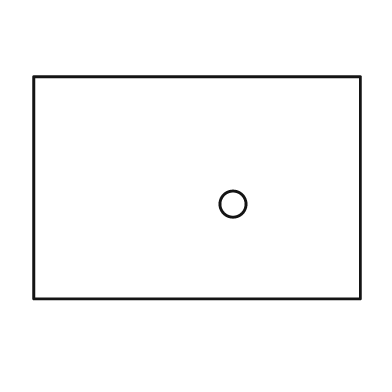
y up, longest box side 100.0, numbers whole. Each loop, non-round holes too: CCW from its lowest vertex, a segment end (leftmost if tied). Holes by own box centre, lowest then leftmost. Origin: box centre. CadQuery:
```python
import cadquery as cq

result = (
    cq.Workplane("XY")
    .moveTo(-50.0, -34.0)
    .lineTo(50.0, -34.0)
    .lineTo(50.0, 34.0)
    .lineTo(-50.0, 34.0)
    .close()
    .moveTo(11.0, -5.0)
    .circle(4.0)
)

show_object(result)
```